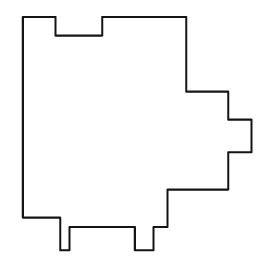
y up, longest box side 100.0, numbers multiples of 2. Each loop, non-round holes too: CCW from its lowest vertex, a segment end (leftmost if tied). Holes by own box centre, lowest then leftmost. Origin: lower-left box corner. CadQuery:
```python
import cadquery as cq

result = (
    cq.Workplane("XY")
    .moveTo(16.0, 0.0)
    .lineTo(20.0, 0.0)
    .lineTo(20.0, 10.0)
    .lineTo(48.0, 10.0)
    .lineTo(48.0, 0.0)
    .lineTo(56.0, 0.0)
    .lineTo(56.0, 10.0)
    .lineTo(62.0, 10.0)
    .lineTo(62.0, 26.0)
    .lineTo(88.0, 26.0)
    .lineTo(88.0, 42.0)
    .lineTo(98.0, 42.0)
    .lineTo(98.0, 56.0)
    .lineTo(88.0, 56.0)
    .lineTo(88.0, 68.0)
    .lineTo(70.0, 68.0)
    .lineTo(70.0, 100.0)
    .lineTo(34.0, 100.0)
    .lineTo(34.0, 92.0)
    .lineTo(14.0, 92.0)
    .lineTo(14.0, 100.0)
    .lineTo(0.0, 100.0)
    .lineTo(0.0, 14.0)
    .lineTo(16.0, 14.0)
    .close()
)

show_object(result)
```